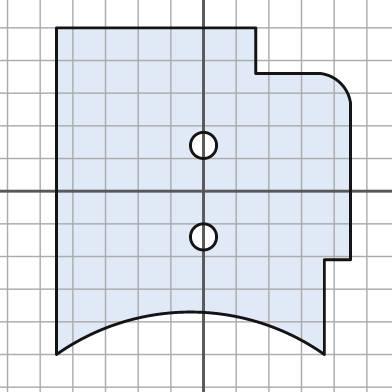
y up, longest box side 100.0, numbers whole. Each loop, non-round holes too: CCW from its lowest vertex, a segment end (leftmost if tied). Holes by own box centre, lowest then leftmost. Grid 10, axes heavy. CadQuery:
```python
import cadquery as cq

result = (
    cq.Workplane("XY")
    .moveTo(-45.0, -50.0)
    .threePointArc((-4.0, -37.0), (37.0, -50.0))
    .lineTo(37.0, -21.0)
    .lineTo(45.0, -21.0)
    .lineTo(45.0, 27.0)
    .threePointArc((42.0, 33.0), (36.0, 36.0))
    .lineTo(16.0, 36.0)
    .lineTo(16.0, 50.0)
    .lineTo(-45.0, 50.0)
    .close()
    .moveTo(0.0, -14.0)
    .circle(4.0)
    .moveTo(0.0, 14.0)
    .circle(4.0)
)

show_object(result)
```